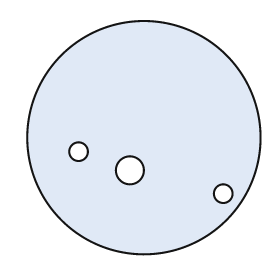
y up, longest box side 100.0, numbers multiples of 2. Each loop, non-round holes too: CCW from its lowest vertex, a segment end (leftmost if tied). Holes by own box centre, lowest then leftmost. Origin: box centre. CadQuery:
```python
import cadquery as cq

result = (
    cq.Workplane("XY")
    .moveTo(0.0, 0.0)
    .circle(50.0)
    .moveTo(34.0, -24.0)
    .circle(4.0)
    .moveTo(-6.0, -14.0)
    .circle(6.0)
    .moveTo(-28.0, -6.0)
    .circle(4.0)
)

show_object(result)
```